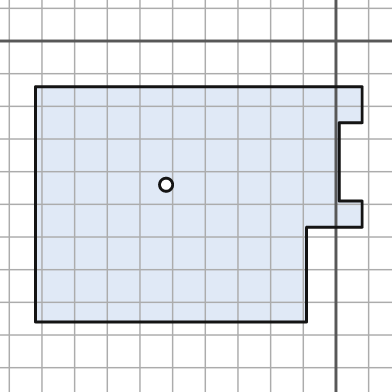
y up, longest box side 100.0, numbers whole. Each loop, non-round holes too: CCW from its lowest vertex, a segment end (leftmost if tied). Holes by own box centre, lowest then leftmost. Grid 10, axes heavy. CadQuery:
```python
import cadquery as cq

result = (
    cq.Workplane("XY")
    .moveTo(-92.0, -86.0)
    .lineTo(-9.0, -86.0)
    .lineTo(-9.0, -57.0)
    .lineTo(8.0, -57.0)
    .lineTo(8.0, -49.0)
    .lineTo(1.0, -49.0)
    .lineTo(1.0, -25.0)
    .lineTo(8.0, -25.0)
    .lineTo(8.0, -14.0)
    .lineTo(-92.0, -14.0)
    .close()
    .moveTo(-52.0, -44.0)
    .circle(2.0)
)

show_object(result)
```